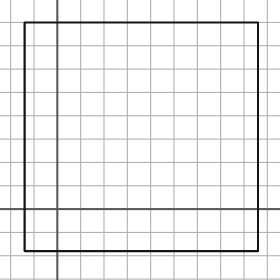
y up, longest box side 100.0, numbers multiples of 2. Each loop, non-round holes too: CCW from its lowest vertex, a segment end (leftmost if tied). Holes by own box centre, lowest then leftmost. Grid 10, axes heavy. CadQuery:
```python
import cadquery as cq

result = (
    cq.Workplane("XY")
    .moveTo(-14.0, -18.0)
    .lineTo(86.0, -18.0)
    .lineTo(86.0, 80.0)
    .lineTo(-14.0, 80.0)
    .close()
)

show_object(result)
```